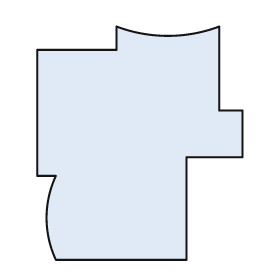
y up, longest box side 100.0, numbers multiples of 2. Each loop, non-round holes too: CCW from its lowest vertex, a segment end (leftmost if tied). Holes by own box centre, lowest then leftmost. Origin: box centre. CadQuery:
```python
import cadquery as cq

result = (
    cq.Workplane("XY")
    .moveTo(-36.0, -50.0)
    .lineTo(20.0, -50.0)
    .lineTo(20.0, -6.0)
    .lineTo(44.0, -6.0)
    .lineTo(44.0, 14.0)
    .lineTo(34.0, 14.0)
    .lineTo(34.0, 50.0)
    .threePointArc((12.0, 46.0), (-10.0, 50.0))
    .lineTo(-10.0, 40.0)
    .lineTo(-44.0, 40.0)
    .lineTo(-44.0, -14.0)
    .lineTo(-36.0, -14.0)
    .threePointArc((-40.0, -32.0), (-36.0, -50.0))
    .close()
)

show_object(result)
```